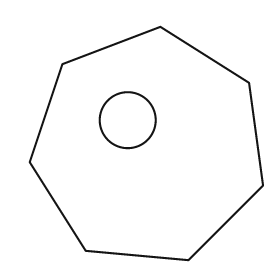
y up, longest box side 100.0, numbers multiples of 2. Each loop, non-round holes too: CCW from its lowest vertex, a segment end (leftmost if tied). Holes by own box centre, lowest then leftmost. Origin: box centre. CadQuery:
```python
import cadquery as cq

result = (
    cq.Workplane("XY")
    .moveTo(18.0, -50.0)
    .lineTo(50.0, -18.0)
    .lineTo(44.0, 26.0)
    .lineTo(6.0, 50.0)
    .lineTo(-36.0, 34.0)
    .lineTo(-50.0, -8.0)
    .lineTo(-26.0, -46.0)
    .close()
    .moveTo(-8.0, 10.0)
    .circle(12.0)
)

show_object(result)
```